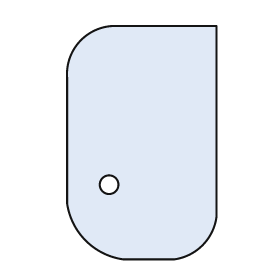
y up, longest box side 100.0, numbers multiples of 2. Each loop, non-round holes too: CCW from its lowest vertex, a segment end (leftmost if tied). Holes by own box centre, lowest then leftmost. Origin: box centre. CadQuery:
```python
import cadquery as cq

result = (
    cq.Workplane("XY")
    .moveTo(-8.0, -50.0)
    .lineTo(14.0, -50.0)
    .threePointArc((26.0, -44.0), (32.0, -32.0))
    .lineTo(32.0, 50.0)
    .lineTo(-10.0, 50.0)
    .threePointArc((-26.0, 44.0), (-32.0, 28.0))
    .lineTo(-32.0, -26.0)
    .threePointArc((-24.0, -42.0), (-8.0, -50.0))
    .close()
    .moveTo(-14.0, -18.0)
    .circle(4.0)
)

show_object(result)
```